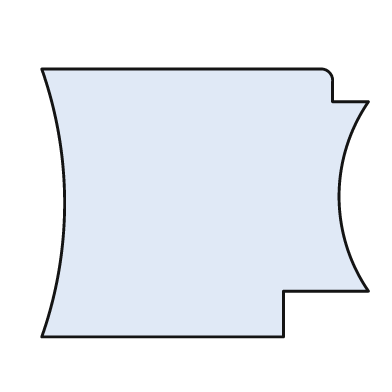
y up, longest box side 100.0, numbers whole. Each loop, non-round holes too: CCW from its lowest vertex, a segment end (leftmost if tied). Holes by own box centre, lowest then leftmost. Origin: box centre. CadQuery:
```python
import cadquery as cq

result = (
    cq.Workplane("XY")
    .moveTo(-50.0, -41.0)
    .lineTo(24.0, -41.0)
    .lineTo(24.0, -27.0)
    .lineTo(50.0, -27.0)
    .threePointArc((41.0, 2.0), (50.0, 31.0))
    .lineTo(39.0, 31.0)
    .lineTo(39.0, 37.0)
    .threePointArc((38.0, 40.0), (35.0, 41.0))
    .lineTo(-50.0, 41.0)
    .threePointArc((-43.0, 0.0), (-50.0, -41.0))
    .close()
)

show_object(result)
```